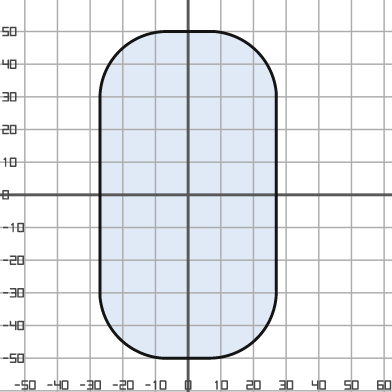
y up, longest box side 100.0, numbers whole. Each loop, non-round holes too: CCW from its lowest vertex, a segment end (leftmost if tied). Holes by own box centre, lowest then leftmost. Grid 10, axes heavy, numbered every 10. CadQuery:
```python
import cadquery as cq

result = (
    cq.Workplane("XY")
    .moveTo(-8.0, -50.0)
    .lineTo(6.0, -50.0)
    .threePointArc((21.0, -44.0), (27.0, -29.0))
    .lineTo(27.0, 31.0)
    .threePointArc((21.0, 44.0), (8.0, 50.0))
    .lineTo(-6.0, 50.0)
    .threePointArc((-21.0, 44.0), (-27.0, 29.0))
    .lineTo(-27.0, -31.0)
    .threePointArc((-21.0, -44.0), (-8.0, -50.0))
    .close()
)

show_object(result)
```